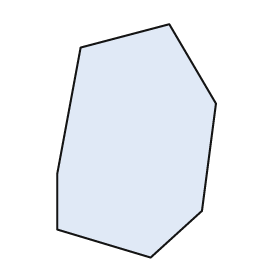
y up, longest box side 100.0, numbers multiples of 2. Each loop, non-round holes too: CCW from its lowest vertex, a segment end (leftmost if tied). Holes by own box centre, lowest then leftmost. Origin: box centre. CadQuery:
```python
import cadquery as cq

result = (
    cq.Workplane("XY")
    .moveTo(6.0, -50.0)
    .lineTo(28.0, -30.0)
    .lineTo(34.0, 16.0)
    .lineTo(14.0, 50.0)
    .lineTo(-24.0, 40.0)
    .lineTo(-34.0, -14.0)
    .lineTo(-34.0, -38.0)
    .close()
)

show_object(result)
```